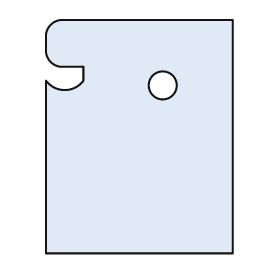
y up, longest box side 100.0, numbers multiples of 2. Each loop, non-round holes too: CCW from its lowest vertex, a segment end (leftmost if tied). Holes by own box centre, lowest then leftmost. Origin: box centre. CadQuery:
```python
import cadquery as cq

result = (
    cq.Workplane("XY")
    .moveTo(-40.0, -50.0)
    .lineTo(40.0, -50.0)
    .lineTo(40.0, 50.0)
    .lineTo(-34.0, 50.0)
    .threePointArc((-38.0, 48.0), (-40.0, 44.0))
    .lineTo(-40.0, 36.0)
    .threePointArc((-38.0, 32.0), (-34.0, 30.0))
    .lineTo(-24.0, 30.0)
    .lineTo(-24.0, 24.0)
    .threePointArc((-32.0, 20.0), (-40.0, 24.0))
    .close()
    .moveTo(10.0, 22.0)
    .circle(6.0)
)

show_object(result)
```